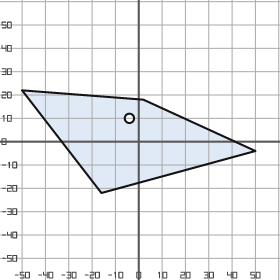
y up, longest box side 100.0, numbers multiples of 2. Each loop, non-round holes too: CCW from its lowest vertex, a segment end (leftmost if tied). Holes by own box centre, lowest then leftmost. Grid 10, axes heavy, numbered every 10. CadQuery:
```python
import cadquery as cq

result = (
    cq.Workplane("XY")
    .moveTo(-16.0, -22.0)
    .lineTo(50.0, -4.0)
    .lineTo(2.0, 18.0)
    .lineTo(-50.0, 22.0)
    .close()
    .moveTo(-4.0, 10.0)
    .circle(2.0)
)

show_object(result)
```